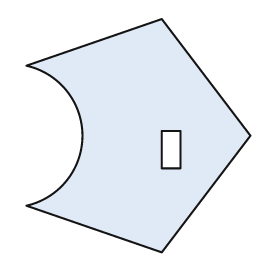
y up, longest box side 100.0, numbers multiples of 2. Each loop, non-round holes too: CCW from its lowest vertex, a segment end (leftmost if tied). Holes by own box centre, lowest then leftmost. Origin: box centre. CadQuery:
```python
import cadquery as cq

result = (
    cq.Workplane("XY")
    .moveTo(10.0, -50.0)
    .lineTo(48.0, 0.0)
    .lineTo(10.0, 50.0)
    .lineTo(-48.0, 30.0)
    .threePointArc((-24.0, 0.0), (-48.0, -30.0))
    .close()
    .moveTo(10.0, -14.0)
    .lineTo(18.0, -14.0)
    .lineTo(18.0, 2.0)
    .lineTo(10.0, 2.0)
    .close()
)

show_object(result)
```